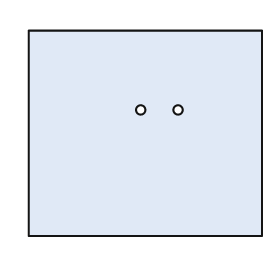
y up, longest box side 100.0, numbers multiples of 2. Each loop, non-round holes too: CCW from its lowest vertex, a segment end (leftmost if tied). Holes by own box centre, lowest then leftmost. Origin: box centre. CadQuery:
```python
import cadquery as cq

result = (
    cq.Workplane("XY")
    .moveTo(-50.0, -44.0)
    .lineTo(50.0, -44.0)
    .lineTo(50.0, 44.0)
    .lineTo(-50.0, 44.0)
    .close()
    .moveTo(-2.0, 10.0)
    .circle(2.0)
    .moveTo(14.0, 10.0)
    .circle(2.0)
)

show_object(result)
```